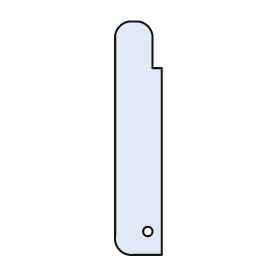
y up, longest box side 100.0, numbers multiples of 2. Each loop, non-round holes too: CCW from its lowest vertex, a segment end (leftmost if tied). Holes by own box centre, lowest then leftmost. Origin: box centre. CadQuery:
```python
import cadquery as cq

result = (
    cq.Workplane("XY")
    .moveTo(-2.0, -50.0)
    .lineTo(10.0, -50.0)
    .lineTo(10.0, 30.0)
    .lineTo(6.0, 30.0)
    .lineTo(6.0, 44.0)
    .threePointArc((4.0, 48.0), (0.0, 50.0))
    .lineTo(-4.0, 50.0)
    .threePointArc((-8.0, 48.0), (-10.0, 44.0))
    .lineTo(-10.0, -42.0)
    .threePointArc((-8.0, -48.0), (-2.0, -50.0))
    .close()
    .moveTo(4.0, -40.0)
    .circle(2.0)
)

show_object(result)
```